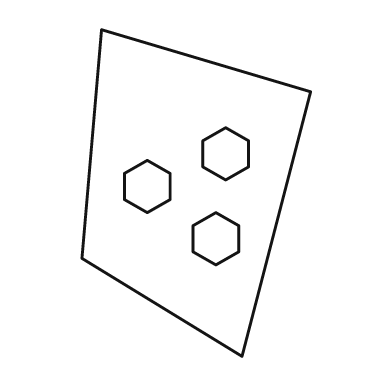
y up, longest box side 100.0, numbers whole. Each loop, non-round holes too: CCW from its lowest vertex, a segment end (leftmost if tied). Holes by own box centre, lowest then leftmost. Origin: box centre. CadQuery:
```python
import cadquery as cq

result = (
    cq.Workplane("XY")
    .moveTo(14.0, -50.0)
    .lineTo(35.0, 31.0)
    .lineTo(-29.0, 50.0)
    .lineTo(-35.0, -20.0)
    .close()
    .moveTo(6.0, -22.0)
    .lineTo(13.0, -18.0)
    .lineTo(13.0, -10.0)
    .lineTo(6.0, -6.0)
    .lineTo(-1.0, -10.0)
    .lineTo(-1.0, -18.0)
    .close()
    .moveTo(-15.0, -6.0)
    .lineTo(-8.0, -2.0)
    .lineTo(-8.0, 6.0)
    .lineTo(-15.0, 10.0)
    .lineTo(-22.0, 6.0)
    .lineTo(-22.0, -2.0)
    .close()
    .moveTo(9.0, 4.0)
    .lineTo(16.0, 8.0)
    .lineTo(16.0, 16.0)
    .lineTo(9.0, 20.0)
    .lineTo(2.0, 16.0)
    .lineTo(2.0, 8.0)
    .close()
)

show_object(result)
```